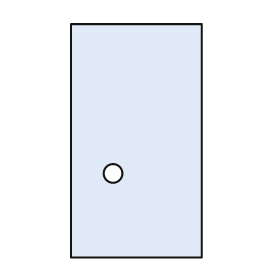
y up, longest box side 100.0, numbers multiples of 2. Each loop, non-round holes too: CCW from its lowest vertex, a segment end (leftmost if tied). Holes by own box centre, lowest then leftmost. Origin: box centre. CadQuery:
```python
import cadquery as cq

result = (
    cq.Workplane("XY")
    .moveTo(-28.0, -50.0)
    .lineTo(28.0, -50.0)
    .lineTo(28.0, 50.0)
    .lineTo(-28.0, 50.0)
    .close()
    .moveTo(-10.0, -14.0)
    .circle(4.0)
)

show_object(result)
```